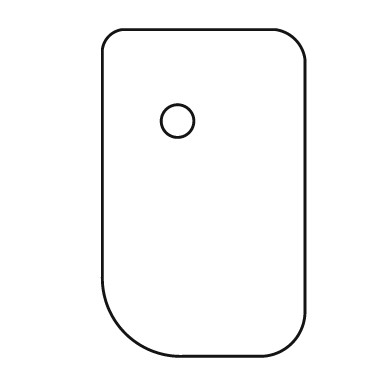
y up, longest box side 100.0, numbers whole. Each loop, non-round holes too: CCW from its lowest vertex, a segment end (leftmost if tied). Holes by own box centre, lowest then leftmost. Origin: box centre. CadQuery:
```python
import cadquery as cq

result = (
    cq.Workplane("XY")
    .moveTo(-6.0, -50.0)
    .lineTo(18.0, -50.0)
    .threePointArc((27.0, -46.0), (31.0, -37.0))
    .lineTo(31.0, 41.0)
    .threePointArc((28.0, 47.0), (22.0, 50.0))
    .lineTo(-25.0, 50.0)
    .threePointArc((-29.0, 48.0), (-31.0, 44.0))
    .lineTo(-31.0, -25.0)
    .threePointArc((-24.0, -43.0), (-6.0, -50.0))
    .close()
    .moveTo(-8.0, 22.0)
    .circle(5.0)
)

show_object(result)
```